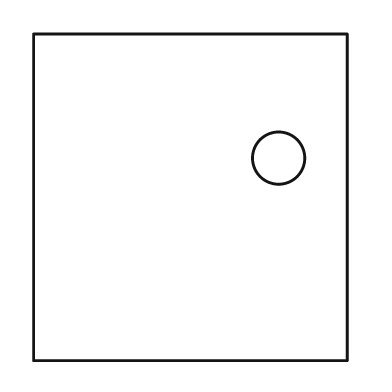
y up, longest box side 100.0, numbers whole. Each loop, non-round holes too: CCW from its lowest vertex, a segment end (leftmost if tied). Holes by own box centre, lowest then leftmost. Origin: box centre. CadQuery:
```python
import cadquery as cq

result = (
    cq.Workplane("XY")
    .moveTo(-48.0, -50.0)
    .lineTo(48.0, -50.0)
    .lineTo(48.0, 50.0)
    .lineTo(-48.0, 50.0)
    .close()
    .moveTo(27.0, 12.0)
    .circle(8.0)
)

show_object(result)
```